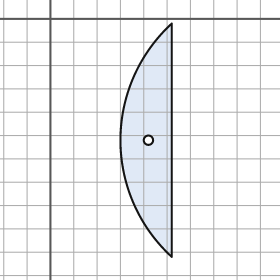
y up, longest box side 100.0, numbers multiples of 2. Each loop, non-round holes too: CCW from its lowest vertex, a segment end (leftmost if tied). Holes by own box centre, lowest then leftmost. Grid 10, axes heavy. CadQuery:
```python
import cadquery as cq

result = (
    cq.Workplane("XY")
    .moveTo(52.0, -102.0)
    .lineTo(52.0, -2.0)
    .threePointArc((30.0, -52.0), (52.0, -102.0))
    .close()
    .moveTo(42.0, -52.0)
    .circle(2.0)
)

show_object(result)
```